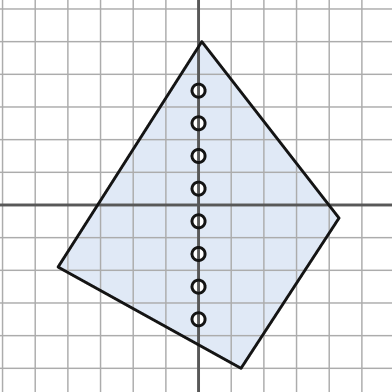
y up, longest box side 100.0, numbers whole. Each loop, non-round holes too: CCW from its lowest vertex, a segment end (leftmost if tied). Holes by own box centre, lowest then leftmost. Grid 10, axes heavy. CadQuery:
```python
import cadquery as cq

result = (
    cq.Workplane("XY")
    .moveTo(13.0, -50.0)
    .lineTo(43.0, -4.0)
    .lineTo(1.0, 50.0)
    .lineTo(-43.0, -19.0)
    .close()
    .moveTo(0.0, -35.0)
    .circle(2.0)
    .moveTo(0.0, -25.0)
    .circle(2.0)
    .moveTo(0.0, -15.0)
    .circle(2.0)
    .moveTo(0.0, -5.0)
    .circle(2.0)
    .moveTo(0.0, 5.0)
    .circle(2.0)
    .moveTo(0.0, 15.0)
    .circle(2.0)
    .moveTo(0.0, 25.0)
    .circle(2.0)
    .moveTo(0.0, 35.0)
    .circle(2.0)
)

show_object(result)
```